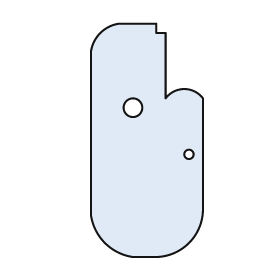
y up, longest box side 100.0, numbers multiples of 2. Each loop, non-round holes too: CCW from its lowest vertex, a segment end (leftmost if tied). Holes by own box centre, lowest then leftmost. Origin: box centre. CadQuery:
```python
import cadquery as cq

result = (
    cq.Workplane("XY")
    .moveTo(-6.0, -50.0)
    .lineTo(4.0, -50.0)
    .threePointArc((18.0, -44.0), (24.0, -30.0))
    .lineTo(24.0, 18.0)
    .threePointArc((16.0, 22.0), (8.0, 18.0))
    .lineTo(8.0, 46.0)
    .lineTo(4.0, 46.0)
    .lineTo(4.0, 50.0)
    .lineTo(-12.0, 50.0)
    .threePointArc((-20.0, 46.0), (-24.0, 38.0))
    .lineTo(-24.0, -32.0)
    .threePointArc((-18.0, -44.0), (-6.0, -50.0))
    .close()
    .moveTo(18.0, -6.0)
    .circle(2.0)
    .moveTo(-6.0, 14.0)
    .circle(4.0)
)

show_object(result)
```